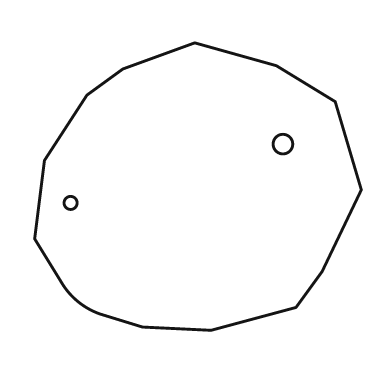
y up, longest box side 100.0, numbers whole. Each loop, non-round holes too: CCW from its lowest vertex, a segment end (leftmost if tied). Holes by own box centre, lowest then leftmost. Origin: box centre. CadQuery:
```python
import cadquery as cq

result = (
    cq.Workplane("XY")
    .moveTo(4.0, -44.0)
    .lineTo(30.0, -37.0)
    .lineTo(38.0, -26.0)
    .lineTo(50.0, -1.0)
    .lineTo(42.0, 26.0)
    .lineTo(24.0, 37.0)
    .lineTo(-1.0, 44.0)
    .lineTo(-23.0, 36.0)
    .lineTo(-34.0, 28.0)
    .lineTo(-47.0, 8.0)
    .lineTo(-50.0, -16.0)
    .lineTo(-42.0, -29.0)
    .threePointArc((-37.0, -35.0), (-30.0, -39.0))
    .lineTo(-17.0, -43.0)
    .close()
    .moveTo(-39.0, -5.0)
    .circle(2.0)
    .moveTo(26.0, 13.0)
    .circle(3.0)
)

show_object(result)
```